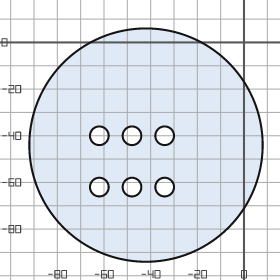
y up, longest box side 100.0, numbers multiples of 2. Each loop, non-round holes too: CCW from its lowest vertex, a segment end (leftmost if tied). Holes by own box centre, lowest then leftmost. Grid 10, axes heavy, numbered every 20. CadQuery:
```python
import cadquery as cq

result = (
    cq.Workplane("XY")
    .moveTo(-42.0, -44.0)
    .circle(50.0)
    .moveTo(-62.0, -62.0)
    .circle(4.0)
    .moveTo(-48.0, -62.0)
    .circle(4.0)
    .moveTo(-34.0, -62.0)
    .circle(4.0)
    .moveTo(-62.0, -40.0)
    .circle(4.0)
    .moveTo(-48.0, -40.0)
    .circle(4.0)
    .moveTo(-34.0, -40.0)
    .circle(4.0)
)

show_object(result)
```